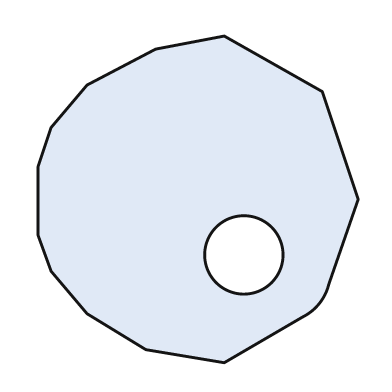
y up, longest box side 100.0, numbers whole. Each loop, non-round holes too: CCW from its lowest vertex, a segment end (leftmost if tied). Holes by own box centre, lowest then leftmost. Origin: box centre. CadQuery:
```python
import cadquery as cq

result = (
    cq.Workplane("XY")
    .moveTo(8.0, -50.0)
    .lineTo(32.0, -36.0)
    .threePointArc((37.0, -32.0), (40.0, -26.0))
    .lineTo(49.0, 0.0)
    .lineTo(38.0, 33.0)
    .lineTo(8.0, 50.0)
    .lineTo(-13.0, 46.0)
    .lineTo(-34.0, 35.0)
    .lineTo(-45.0, 22.0)
    .lineTo(-49.0, 10.0)
    .lineTo(-49.0, -11.0)
    .lineTo(-45.0, -22.0)
    .lineTo(-34.0, -35.0)
    .lineTo(-16.0, -46.0)
    .close()
    .moveTo(14.0, -17.0)
    .circle(12.0)
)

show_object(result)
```